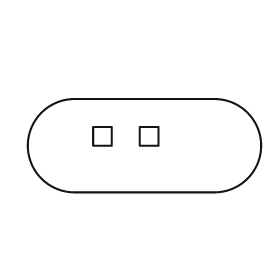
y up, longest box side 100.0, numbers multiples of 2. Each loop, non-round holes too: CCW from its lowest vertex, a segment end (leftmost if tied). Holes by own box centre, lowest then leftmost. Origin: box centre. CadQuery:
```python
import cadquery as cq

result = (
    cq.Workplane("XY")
    .moveTo(-30.0, -20.0)
    .lineTo(30.0, -20.0)
    .threePointArc((50.0, 0.0), (30.0, 20.0))
    .lineTo(-30.0, 20.0)
    .threePointArc((-50.0, 0.0), (-30.0, -20.0))
    .close()
    .moveTo(-22.0, 0.0)
    .lineTo(-14.0, 0.0)
    .lineTo(-14.0, 8.0)
    .lineTo(-22.0, 8.0)
    .close()
    .moveTo(-2.0, 0.0)
    .lineTo(6.0, 0.0)
    .lineTo(6.0, 8.0)
    .lineTo(-2.0, 8.0)
    .close()
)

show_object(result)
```